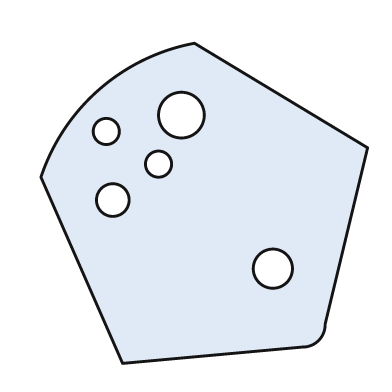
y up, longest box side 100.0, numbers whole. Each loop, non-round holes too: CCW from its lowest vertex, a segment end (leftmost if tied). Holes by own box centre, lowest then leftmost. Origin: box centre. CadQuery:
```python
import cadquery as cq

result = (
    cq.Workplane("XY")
    .moveTo(-25.0, -49.0)
    .lineTo(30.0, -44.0)
    .threePointArc((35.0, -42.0), (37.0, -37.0))
    .lineTo(50.0, 17.0)
    .lineTo(-3.0, 49.0)
    .threePointArc((-32.0, 35.0), (-50.0, 8.0))
    .close()
    .moveTo(21.0, -20.0)
    .circle(6.0)
    .moveTo(-28.0, 1.0)
    .circle(5.0)
    .moveTo(-14.0, 12.0)
    .circle(4.0)
    .moveTo(-30.0, 22.0)
    .circle(4.0)
    .moveTo(-7.0, 27.0)
    .circle(7.0)
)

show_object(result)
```